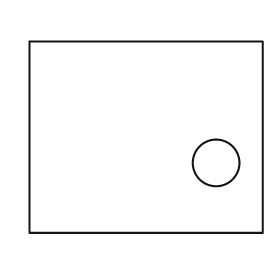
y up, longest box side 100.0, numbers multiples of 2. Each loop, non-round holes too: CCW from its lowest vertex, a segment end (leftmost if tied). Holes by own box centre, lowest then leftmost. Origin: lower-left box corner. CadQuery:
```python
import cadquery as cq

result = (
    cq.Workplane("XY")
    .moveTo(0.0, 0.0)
    .lineTo(100.0, 0.0)
    .lineTo(100.0, 82.0)
    .lineTo(0.0, 82.0)
    .close()
    .moveTo(80.0, 30.0)
    .circle(10.0)
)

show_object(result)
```